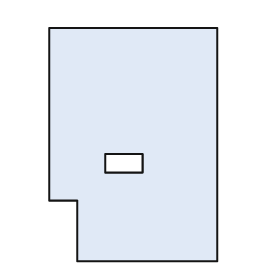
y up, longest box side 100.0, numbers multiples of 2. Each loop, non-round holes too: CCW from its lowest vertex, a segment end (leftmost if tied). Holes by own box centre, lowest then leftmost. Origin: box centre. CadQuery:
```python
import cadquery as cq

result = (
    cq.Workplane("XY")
    .moveTo(-24.0, -50.0)
    .lineTo(36.0, -50.0)
    .lineTo(36.0, 50.0)
    .lineTo(-36.0, 50.0)
    .lineTo(-36.0, -24.0)
    .lineTo(-24.0, -24.0)
    .close()
    .moveTo(-12.0, -12.0)
    .lineTo(4.0, -12.0)
    .lineTo(4.0, -4.0)
    .lineTo(-12.0, -4.0)
    .close()
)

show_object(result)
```